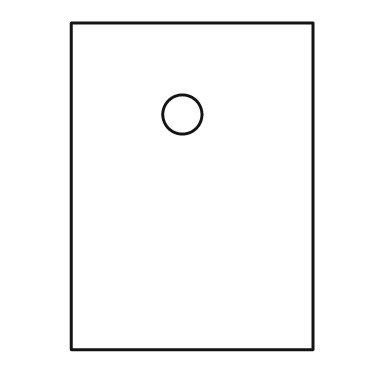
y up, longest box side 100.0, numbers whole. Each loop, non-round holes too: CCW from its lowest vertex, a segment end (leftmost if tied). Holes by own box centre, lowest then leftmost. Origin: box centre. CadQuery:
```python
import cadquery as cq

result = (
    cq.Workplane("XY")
    .moveTo(-37.0, -50.0)
    .lineTo(37.0, -50.0)
    .lineTo(37.0, 50.0)
    .lineTo(-37.0, 50.0)
    .close()
    .moveTo(-3.0, 22.0)
    .circle(6.0)
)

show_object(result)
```